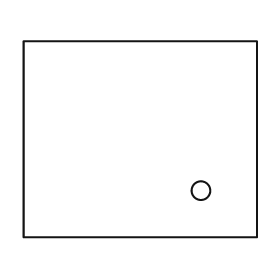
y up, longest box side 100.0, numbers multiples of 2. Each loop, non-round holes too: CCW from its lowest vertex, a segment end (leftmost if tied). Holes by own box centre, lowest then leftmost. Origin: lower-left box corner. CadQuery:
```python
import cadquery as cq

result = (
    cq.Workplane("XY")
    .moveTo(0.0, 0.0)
    .lineTo(100.0, 0.0)
    .lineTo(100.0, 84.0)
    .lineTo(0.0, 84.0)
    .close()
    .moveTo(76.0, 20.0)
    .circle(4.0)
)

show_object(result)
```